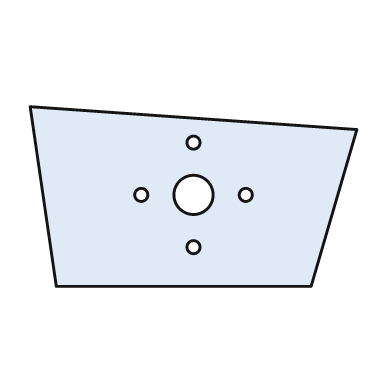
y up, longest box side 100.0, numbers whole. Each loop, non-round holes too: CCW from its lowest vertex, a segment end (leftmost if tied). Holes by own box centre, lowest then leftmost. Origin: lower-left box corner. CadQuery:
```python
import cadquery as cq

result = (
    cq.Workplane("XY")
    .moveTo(8.0, 0.0)
    .lineTo(86.0, 0.0)
    .lineTo(100.0, 48.0)
    .lineTo(0.0, 55.0)
    .close()
    .moveTo(50.0, 12.0)
    .circle(2.0)
    .moveTo(34.0, 28.0)
    .circle(2.0)
    .moveTo(50.0, 28.0)
    .circle(6.0)
    .moveTo(66.0, 28.0)
    .circle(2.0)
    .moveTo(50.0, 44.0)
    .circle(2.0)
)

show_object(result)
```